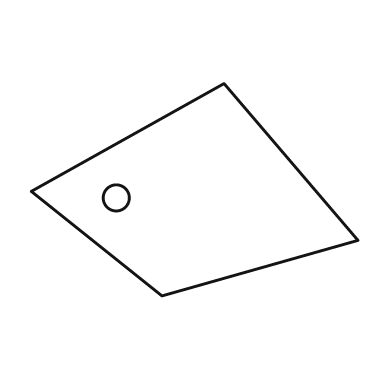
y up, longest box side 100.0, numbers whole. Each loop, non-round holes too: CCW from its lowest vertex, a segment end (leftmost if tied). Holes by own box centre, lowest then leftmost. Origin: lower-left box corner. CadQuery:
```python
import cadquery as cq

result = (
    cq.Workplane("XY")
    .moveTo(40.0, 0.0)
    .lineTo(100.0, 17.0)
    .lineTo(59.0, 65.0)
    .lineTo(0.0, 32.0)
    .close()
    .moveTo(26.0, 30.0)
    .circle(4.0)
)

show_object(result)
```